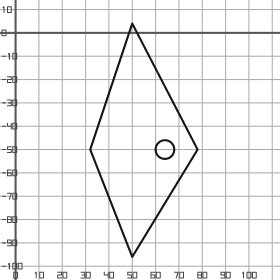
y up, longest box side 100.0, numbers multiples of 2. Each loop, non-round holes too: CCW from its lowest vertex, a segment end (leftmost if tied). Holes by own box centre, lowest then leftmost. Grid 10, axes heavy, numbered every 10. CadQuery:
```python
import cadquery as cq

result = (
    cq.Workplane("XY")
    .moveTo(50.0, -96.0)
    .lineTo(78.0, -50.0)
    .lineTo(50.0, 4.0)
    .lineTo(32.0, -50.0)
    .close()
    .moveTo(64.0, -50.0)
    .circle(4.0)
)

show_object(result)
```